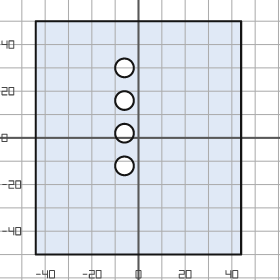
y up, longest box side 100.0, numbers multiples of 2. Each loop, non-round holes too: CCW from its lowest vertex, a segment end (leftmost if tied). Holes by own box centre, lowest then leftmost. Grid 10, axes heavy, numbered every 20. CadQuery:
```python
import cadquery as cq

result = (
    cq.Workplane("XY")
    .moveTo(-44.0, -50.0)
    .lineTo(44.0, -50.0)
    .lineTo(44.0, 50.0)
    .lineTo(-44.0, 50.0)
    .close()
    .moveTo(-6.0, -12.0)
    .circle(4.0)
    .moveTo(-6.0, 2.0)
    .circle(4.0)
    .moveTo(-6.0, 16.0)
    .circle(4.0)
    .moveTo(-6.0, 30.0)
    .circle(4.0)
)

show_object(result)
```